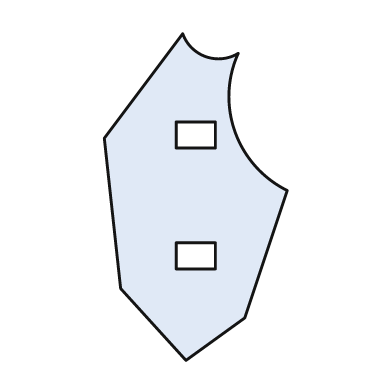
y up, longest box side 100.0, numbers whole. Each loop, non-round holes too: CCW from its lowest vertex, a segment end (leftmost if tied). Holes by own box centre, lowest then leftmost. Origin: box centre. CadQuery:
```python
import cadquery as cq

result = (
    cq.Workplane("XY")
    .moveTo(-3.0, -50.0)
    .lineTo(15.0, -37.0)
    .lineTo(28.0, 2.0)
    .threePointArc((12.0, 20.0), (13.0, 44.0))
    .threePointArc((3.0, 43.0), (-4.0, 50.0))
    .lineTo(-28.0, 18.0)
    .lineTo(-23.0, -28.0)
    .close()
    .moveTo(-6.0, -22.0)
    .lineTo(6.0, -22.0)
    .lineTo(6.0, -14.0)
    .lineTo(-6.0, -14.0)
    .close()
    .moveTo(-6.0, 15.0)
    .lineTo(6.0, 15.0)
    .lineTo(6.0, 23.0)
    .lineTo(-6.0, 23.0)
    .close()
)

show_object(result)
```